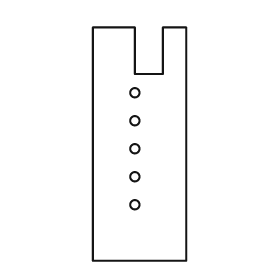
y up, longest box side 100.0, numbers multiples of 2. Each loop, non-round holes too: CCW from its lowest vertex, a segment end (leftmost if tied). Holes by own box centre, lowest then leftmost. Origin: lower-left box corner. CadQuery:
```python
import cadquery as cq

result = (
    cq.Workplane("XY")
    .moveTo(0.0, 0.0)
    .lineTo(40.0, 0.0)
    .lineTo(40.0, 100.0)
    .lineTo(30.0, 100.0)
    .lineTo(30.0, 80.0)
    .lineTo(18.0, 80.0)
    .lineTo(18.0, 100.0)
    .lineTo(0.0, 100.0)
    .close()
    .moveTo(18.0, 24.0)
    .circle(2.0)
    .moveTo(18.0, 36.0)
    .circle(2.0)
    .moveTo(18.0, 48.0)
    .circle(2.0)
    .moveTo(18.0, 60.0)
    .circle(2.0)
    .moveTo(18.0, 72.0)
    .circle(2.0)
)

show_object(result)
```